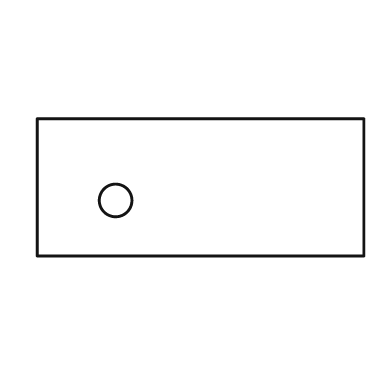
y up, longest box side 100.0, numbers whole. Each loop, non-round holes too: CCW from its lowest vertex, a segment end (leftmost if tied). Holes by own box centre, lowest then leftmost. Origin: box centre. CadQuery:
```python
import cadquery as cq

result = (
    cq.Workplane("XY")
    .moveTo(-50.0, -21.0)
    .lineTo(50.0, -21.0)
    .lineTo(50.0, 21.0)
    .lineTo(-50.0, 21.0)
    .close()
    .moveTo(-26.0, -4.0)
    .circle(5.0)
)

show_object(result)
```